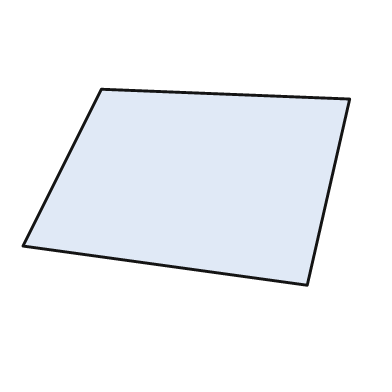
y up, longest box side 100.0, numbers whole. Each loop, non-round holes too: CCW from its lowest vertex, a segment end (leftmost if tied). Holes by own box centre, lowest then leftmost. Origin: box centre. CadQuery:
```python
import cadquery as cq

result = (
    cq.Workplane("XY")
    .moveTo(37.0, -30.0)
    .lineTo(50.0, 27.0)
    .lineTo(-26.0, 30.0)
    .lineTo(-50.0, -18.0)
    .close()
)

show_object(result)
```